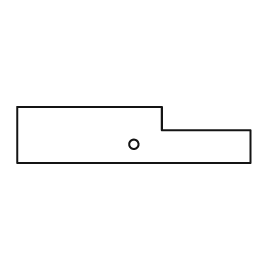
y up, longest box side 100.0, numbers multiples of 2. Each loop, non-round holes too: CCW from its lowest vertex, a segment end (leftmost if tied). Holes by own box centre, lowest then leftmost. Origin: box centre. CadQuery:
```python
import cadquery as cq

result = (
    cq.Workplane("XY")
    .moveTo(-50.0, -12.0)
    .lineTo(50.0, -12.0)
    .lineTo(50.0, 2.0)
    .lineTo(12.0, 2.0)
    .lineTo(12.0, 12.0)
    .lineTo(-50.0, 12.0)
    .close()
    .moveTo(0.0, -4.0)
    .circle(2.0)
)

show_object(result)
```